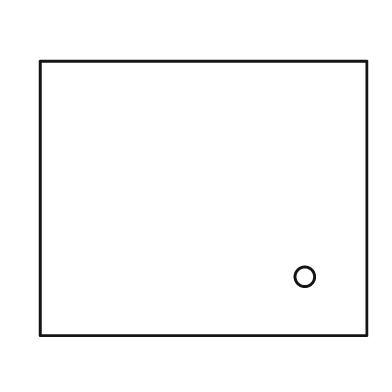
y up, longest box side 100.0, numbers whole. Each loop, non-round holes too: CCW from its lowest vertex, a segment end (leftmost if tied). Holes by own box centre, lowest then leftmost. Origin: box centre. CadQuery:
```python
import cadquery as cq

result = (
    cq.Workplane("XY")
    .moveTo(-50.0, -42.0)
    .lineTo(50.0, -42.0)
    .lineTo(50.0, 42.0)
    .lineTo(-50.0, 42.0)
    .close()
    .moveTo(31.0, -24.0)
    .circle(3.0)
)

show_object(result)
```